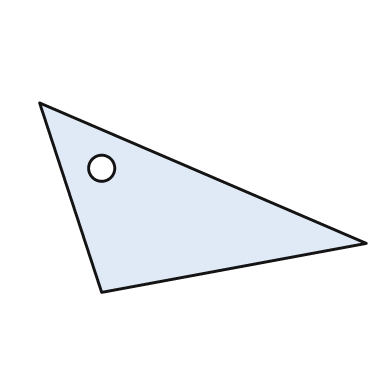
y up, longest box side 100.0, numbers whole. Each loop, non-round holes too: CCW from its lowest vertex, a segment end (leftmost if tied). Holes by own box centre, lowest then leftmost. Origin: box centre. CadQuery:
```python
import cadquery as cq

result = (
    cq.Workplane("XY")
    .moveTo(-31.0, -29.0)
    .lineTo(50.0, -14.0)
    .lineTo(-50.0, 29.0)
    .close()
    .moveTo(-31.0, 9.0)
    .circle(4.0)
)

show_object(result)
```